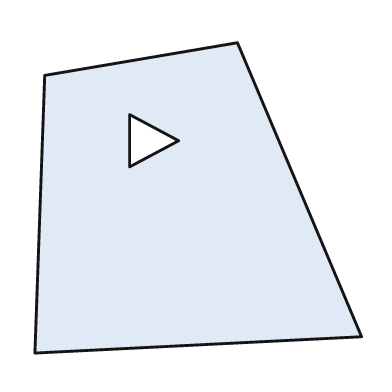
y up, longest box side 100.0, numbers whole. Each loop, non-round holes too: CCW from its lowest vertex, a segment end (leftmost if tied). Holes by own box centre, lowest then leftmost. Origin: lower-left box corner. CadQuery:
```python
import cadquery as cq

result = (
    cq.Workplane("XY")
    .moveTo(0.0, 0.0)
    .lineTo(100.0, 5.0)
    .lineTo(62.0, 95.0)
    .lineTo(3.0, 85.0)
    .close()
    .moveTo(29.0, 57.0)
    .lineTo(44.0, 65.0)
    .lineTo(29.0, 73.0)
    .close()
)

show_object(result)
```